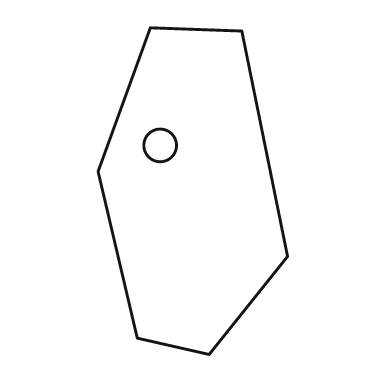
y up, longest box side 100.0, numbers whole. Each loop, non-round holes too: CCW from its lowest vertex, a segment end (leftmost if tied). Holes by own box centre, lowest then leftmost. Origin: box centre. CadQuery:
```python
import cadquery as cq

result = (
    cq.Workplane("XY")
    .moveTo(5.0, -50.0)
    .lineTo(29.0, -20.0)
    .lineTo(15.0, 49.0)
    .lineTo(-13.0, 50.0)
    .lineTo(-29.0, 6.0)
    .lineTo(-17.0, -45.0)
    .close()
    .moveTo(-10.0, 14.0)
    .circle(5.0)
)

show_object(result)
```